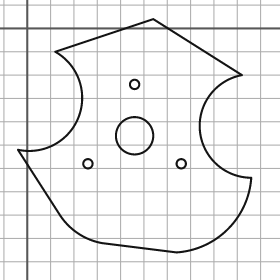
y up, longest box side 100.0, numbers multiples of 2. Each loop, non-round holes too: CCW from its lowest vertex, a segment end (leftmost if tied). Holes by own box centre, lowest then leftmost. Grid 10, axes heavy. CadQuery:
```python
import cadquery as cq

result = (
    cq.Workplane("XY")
    .moveTo(64.0, -96.0)
    .threePointArc((86.0, -86.0), (96.0, -64.0))
    .threePointArc((74.0, -44.0), (92.0, -20.0))
    .lineTo(54.0, 4.0)
    .lineTo(12.0, -10.0)
    .threePointArc((22.0, -38.0), (-4.0, -52.0))
    .lineTo(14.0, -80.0)
    .threePointArc((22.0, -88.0), (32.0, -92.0))
    .close()
    .moveTo(26.0, -58.0)
    .circle(2.0)
    .moveTo(66.0, -58.0)
    .circle(2.0)
    .moveTo(46.0, -46.0)
    .circle(8.0)
    .moveTo(46.0, -24.0)
    .circle(2.0)
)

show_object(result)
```